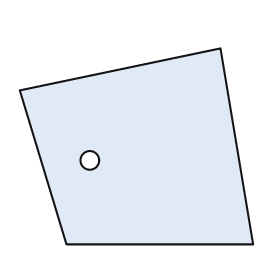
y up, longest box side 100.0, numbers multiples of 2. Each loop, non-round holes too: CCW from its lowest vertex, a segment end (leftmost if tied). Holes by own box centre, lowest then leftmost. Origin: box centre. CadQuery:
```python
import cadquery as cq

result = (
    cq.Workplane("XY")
    .moveTo(-30.0, -42.0)
    .lineTo(50.0, -42.0)
    .lineTo(36.0, 42.0)
    .lineTo(-50.0, 24.0)
    .close()
    .moveTo(-20.0, -6.0)
    .circle(4.0)
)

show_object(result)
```